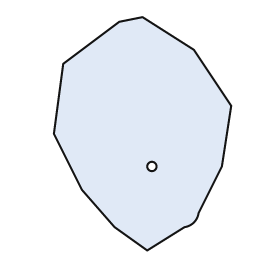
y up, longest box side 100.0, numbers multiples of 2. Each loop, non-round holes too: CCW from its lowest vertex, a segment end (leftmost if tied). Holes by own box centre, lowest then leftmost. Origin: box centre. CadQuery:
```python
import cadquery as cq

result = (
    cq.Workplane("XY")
    .moveTo(2.0, -50.0)
    .lineTo(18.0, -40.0)
    .threePointArc((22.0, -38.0), (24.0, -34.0))
    .lineTo(34.0, -14.0)
    .lineTo(38.0, 12.0)
    .lineTo(22.0, 36.0)
    .lineTo(0.0, 50.0)
    .lineTo(-10.0, 48.0)
    .lineTo(-34.0, 30.0)
    .lineTo(-38.0, 0.0)
    .lineTo(-26.0, -24.0)
    .lineTo(-12.0, -40.0)
    .close()
    .moveTo(4.0, -14.0)
    .circle(2.0)
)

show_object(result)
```